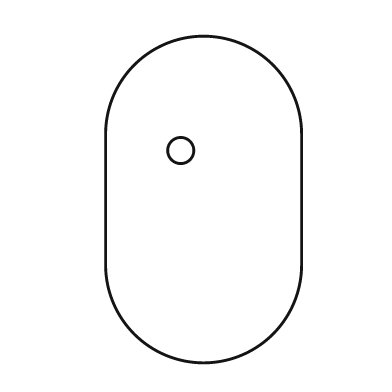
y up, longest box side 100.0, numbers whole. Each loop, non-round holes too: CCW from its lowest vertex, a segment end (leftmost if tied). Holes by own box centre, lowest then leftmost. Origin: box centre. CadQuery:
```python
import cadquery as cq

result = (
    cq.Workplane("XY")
    .moveTo(-30.0, -20.0)
    .threePointArc((0.0, -50.0), (30.0, -20.0))
    .lineTo(30.0, 20.0)
    .threePointArc((0.0, 50.0), (-30.0, 20.0))
    .close()
    .moveTo(-7.0, 15.0)
    .circle(4.0)
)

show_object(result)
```